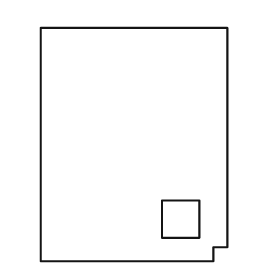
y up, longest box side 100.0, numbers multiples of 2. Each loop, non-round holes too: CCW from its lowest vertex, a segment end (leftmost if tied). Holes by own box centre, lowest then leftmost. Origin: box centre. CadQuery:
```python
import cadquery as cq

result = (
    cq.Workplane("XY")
    .moveTo(-40.0, -50.0)
    .lineTo(34.0, -50.0)
    .lineTo(34.0, -44.0)
    .lineTo(40.0, -44.0)
    .lineTo(40.0, 50.0)
    .lineTo(-40.0, 50.0)
    .close()
    .moveTo(12.0, -40.0)
    .lineTo(28.0, -40.0)
    .lineTo(28.0, -24.0)
    .lineTo(12.0, -24.0)
    .close()
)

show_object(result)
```